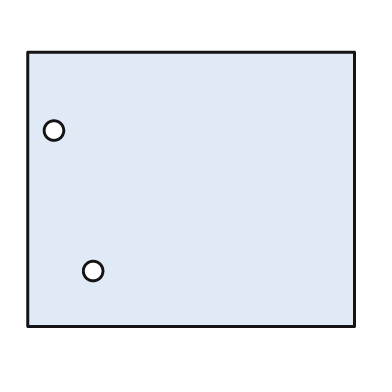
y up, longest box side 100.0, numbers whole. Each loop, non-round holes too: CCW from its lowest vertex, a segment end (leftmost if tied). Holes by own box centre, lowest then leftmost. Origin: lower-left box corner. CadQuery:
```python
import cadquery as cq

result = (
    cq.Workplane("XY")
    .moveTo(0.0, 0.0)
    .lineTo(100.0, 0.0)
    .lineTo(100.0, 84.0)
    .lineTo(0.0, 84.0)
    .close()
    .moveTo(20.0, 17.0)
    .circle(3.0)
    .moveTo(8.0, 60.0)
    .circle(3.0)
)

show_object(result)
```